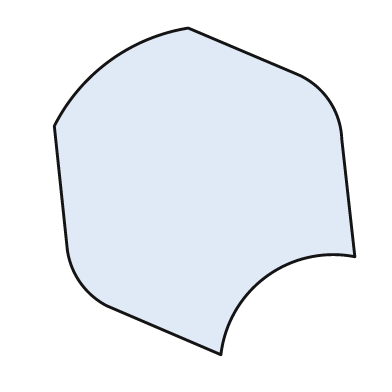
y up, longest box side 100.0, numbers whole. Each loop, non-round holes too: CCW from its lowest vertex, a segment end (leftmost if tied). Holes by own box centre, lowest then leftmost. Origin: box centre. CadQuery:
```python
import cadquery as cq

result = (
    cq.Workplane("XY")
    .moveTo(5.0, -50.0)
    .threePointArc((19.0, -26.0), (46.0, -20.0))
    .lineTo(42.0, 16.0)
    .threePointArc((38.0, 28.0), (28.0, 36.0))
    .lineTo(-5.0, 50.0)
    .threePointArc((-29.0, 40.0), (-46.0, 20.0))
    .lineTo(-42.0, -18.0)
    .threePointArc((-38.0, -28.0), (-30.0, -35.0))
    .close()
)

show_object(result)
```